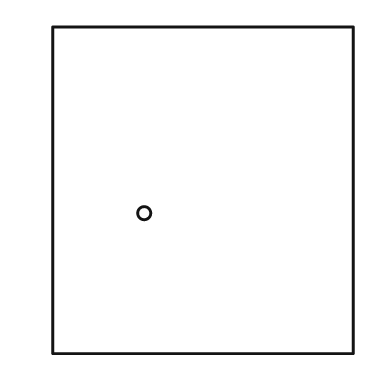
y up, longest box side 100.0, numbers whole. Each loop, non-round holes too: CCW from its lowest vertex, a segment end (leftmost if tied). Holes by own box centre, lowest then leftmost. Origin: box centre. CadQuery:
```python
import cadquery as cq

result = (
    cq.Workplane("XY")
    .moveTo(-46.0, -50.0)
    .lineTo(46.0, -50.0)
    .lineTo(46.0, 50.0)
    .lineTo(-46.0, 50.0)
    .close()
    .moveTo(-18.0, -7.0)
    .circle(2.0)
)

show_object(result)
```